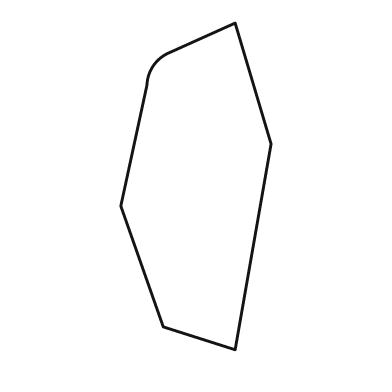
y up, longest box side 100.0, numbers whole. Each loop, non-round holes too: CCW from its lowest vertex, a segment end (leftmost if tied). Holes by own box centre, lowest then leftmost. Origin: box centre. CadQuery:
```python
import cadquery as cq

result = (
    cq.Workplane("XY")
    .moveTo(12.0, -50.0)
    .lineTo(23.0, 13.0)
    .lineTo(12.0, 50.0)
    .lineTo(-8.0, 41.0)
    .threePointArc((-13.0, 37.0), (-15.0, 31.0))
    .lineTo(-23.0, -6.0)
    .lineTo(-10.0, -43.0)
    .close()
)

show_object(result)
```